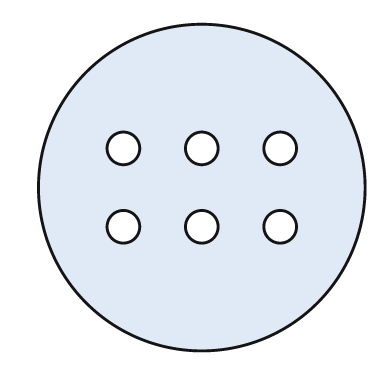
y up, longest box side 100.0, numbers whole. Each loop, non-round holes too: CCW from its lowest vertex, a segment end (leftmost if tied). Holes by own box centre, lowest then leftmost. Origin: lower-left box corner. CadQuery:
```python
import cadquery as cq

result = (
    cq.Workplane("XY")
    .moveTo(50.0, 50.0)
    .circle(50.0)
    .moveTo(26.0, 38.0)
    .circle(5.0)
    .moveTo(50.0, 38.0)
    .circle(5.0)
    .moveTo(74.0, 38.0)
    .circle(5.0)
    .moveTo(26.0, 62.0)
    .circle(5.0)
    .moveTo(50.0, 62.0)
    .circle(5.0)
    .moveTo(74.0, 62.0)
    .circle(5.0)
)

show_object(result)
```